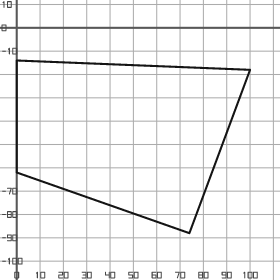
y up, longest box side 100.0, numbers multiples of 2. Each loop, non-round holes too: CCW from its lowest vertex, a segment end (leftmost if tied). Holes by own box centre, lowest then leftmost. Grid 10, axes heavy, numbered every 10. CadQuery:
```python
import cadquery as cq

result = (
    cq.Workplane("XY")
    .moveTo(74.0, -88.0)
    .lineTo(100.0, -18.0)
    .lineTo(0.0, -14.0)
    .lineTo(0.0, -62.0)
    .close()
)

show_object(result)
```